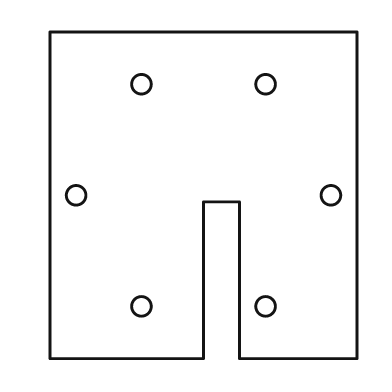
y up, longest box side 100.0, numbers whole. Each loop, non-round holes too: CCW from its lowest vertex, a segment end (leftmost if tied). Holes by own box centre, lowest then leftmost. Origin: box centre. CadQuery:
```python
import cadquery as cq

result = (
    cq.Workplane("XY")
    .moveTo(-47.0, -50.0)
    .lineTo(0.0, -50.0)
    .lineTo(0.0, -2.0)
    .lineTo(11.0, -2.0)
    .lineTo(11.0, -50.0)
    .lineTo(47.0, -50.0)
    .lineTo(47.0, 50.0)
    .lineTo(-47.0, 50.0)
    .close()
    .moveTo(-19.0, -34.0)
    .circle(3.0)
    .moveTo(19.0, -34.0)
    .circle(3.0)
    .moveTo(-39.0, 0.0)
    .circle(3.0)
    .moveTo(39.0, 0.0)
    .circle(3.0)
    .moveTo(-19.0, 34.0)
    .circle(3.0)
    .moveTo(19.0, 34.0)
    .circle(3.0)
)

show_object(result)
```